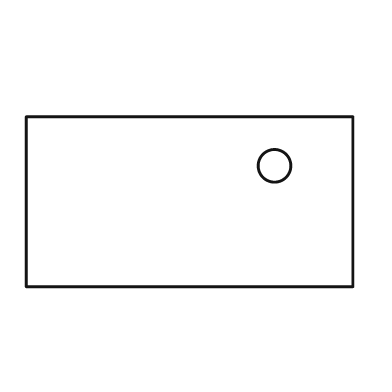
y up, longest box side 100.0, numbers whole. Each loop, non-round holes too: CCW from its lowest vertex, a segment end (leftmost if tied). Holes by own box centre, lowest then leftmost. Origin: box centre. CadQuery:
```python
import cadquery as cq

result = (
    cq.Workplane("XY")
    .moveTo(-50.0, -26.0)
    .lineTo(50.0, -26.0)
    .lineTo(50.0, 26.0)
    .lineTo(-50.0, 26.0)
    .close()
    .moveTo(26.0, 11.0)
    .circle(5.0)
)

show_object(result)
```